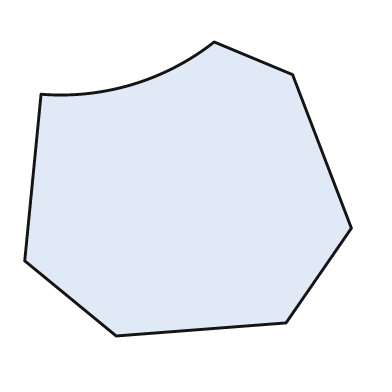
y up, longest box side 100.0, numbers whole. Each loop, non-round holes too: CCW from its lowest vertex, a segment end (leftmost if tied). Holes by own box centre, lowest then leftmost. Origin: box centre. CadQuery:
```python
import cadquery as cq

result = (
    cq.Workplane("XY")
    .moveTo(-22.0, -45.0)
    .lineTo(30.0, -41.0)
    .lineTo(50.0, -12.0)
    .lineTo(32.0, 35.0)
    .lineTo(8.0, 45.0)
    .threePointArc((-17.0, 32.0), (-45.0, 29.0))
    .lineTo(-50.0, -22.0)
    .close()
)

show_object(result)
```